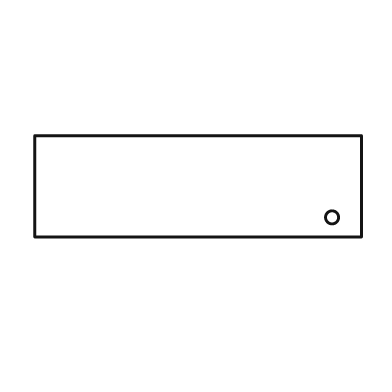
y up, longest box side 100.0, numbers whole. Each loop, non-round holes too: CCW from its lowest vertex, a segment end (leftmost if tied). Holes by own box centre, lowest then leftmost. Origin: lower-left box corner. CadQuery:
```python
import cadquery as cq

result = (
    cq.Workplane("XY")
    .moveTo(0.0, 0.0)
    .lineTo(100.0, 0.0)
    .lineTo(100.0, 31.0)
    .lineTo(0.0, 31.0)
    .close()
    .moveTo(91.0, 6.0)
    .circle(2.0)
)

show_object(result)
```